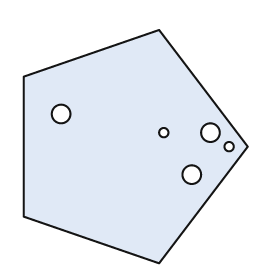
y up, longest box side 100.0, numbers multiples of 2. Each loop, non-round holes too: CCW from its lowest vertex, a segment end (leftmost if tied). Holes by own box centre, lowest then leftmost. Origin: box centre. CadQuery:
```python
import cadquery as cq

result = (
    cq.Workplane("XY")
    .moveTo(10.0, -50.0)
    .lineTo(48.0, 0.0)
    .lineTo(10.0, 50.0)
    .lineTo(-48.0, 30.0)
    .lineTo(-48.0, -30.0)
    .close()
    .moveTo(24.0, -12.0)
    .circle(4.0)
    .moveTo(40.0, 0.0)
    .circle(2.0)
    .moveTo(12.0, 6.0)
    .circle(2.0)
    .moveTo(32.0, 6.0)
    .circle(4.0)
    .moveTo(-32.0, 14.0)
    .circle(4.0)
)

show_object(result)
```